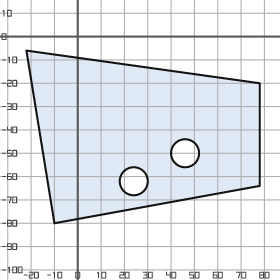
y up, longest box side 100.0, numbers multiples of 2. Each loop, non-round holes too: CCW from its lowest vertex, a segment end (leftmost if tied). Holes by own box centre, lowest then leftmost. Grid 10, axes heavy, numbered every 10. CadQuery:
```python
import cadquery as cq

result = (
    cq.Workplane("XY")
    .moveTo(-10.0, -80.0)
    .lineTo(78.0, -64.0)
    .lineTo(78.0, -20.0)
    .lineTo(-22.0, -6.0)
    .close()
    .moveTo(24.0, -62.0)
    .circle(6.0)
    .moveTo(46.0, -50.0)
    .circle(6.0)
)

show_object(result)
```